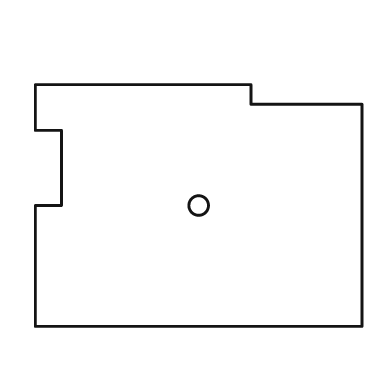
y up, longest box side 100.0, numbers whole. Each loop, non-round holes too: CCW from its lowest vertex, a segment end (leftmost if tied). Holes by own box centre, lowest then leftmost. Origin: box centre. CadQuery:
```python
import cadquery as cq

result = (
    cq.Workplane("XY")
    .moveTo(-50.0, -37.0)
    .lineTo(50.0, -37.0)
    .lineTo(50.0, 31.0)
    .lineTo(16.0, 31.0)
    .lineTo(16.0, 37.0)
    .lineTo(-50.0, 37.0)
    .lineTo(-50.0, 23.0)
    .lineTo(-42.0, 23.0)
    .lineTo(-42.0, 0.0)
    .lineTo(-50.0, 0.0)
    .close()
    .moveTo(0.0, 0.0)
    .circle(3.0)
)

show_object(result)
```